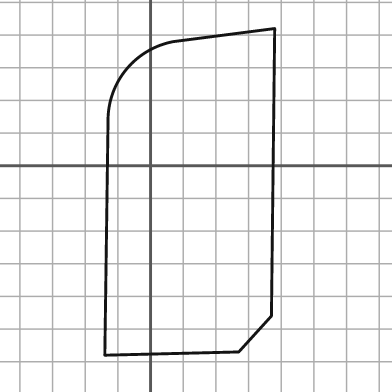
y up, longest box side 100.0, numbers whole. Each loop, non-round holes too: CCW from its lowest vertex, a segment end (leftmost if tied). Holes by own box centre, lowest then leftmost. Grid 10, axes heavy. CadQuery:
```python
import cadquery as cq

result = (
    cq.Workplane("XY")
    .moveTo(-14.0, -58.0)
    .lineTo(27.0, -57.0)
    .lineTo(37.0, -46.0)
    .lineTo(38.0, 42.0)
    .lineTo(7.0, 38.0)
    .threePointArc((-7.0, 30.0), (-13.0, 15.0))
    .close()
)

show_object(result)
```